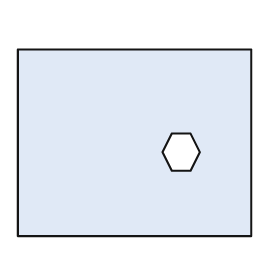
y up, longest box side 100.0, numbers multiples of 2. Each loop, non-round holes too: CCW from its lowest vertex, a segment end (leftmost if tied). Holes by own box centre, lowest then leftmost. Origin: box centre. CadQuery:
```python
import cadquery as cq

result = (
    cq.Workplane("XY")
    .moveTo(-50.0, -40.0)
    .lineTo(50.0, -40.0)
    .lineTo(50.0, 40.0)
    .lineTo(-50.0, 40.0)
    .close()
    .moveTo(16.0, -12.0)
    .lineTo(24.0, -12.0)
    .lineTo(28.0, -4.0)
    .lineTo(24.0, 4.0)
    .lineTo(16.0, 4.0)
    .lineTo(12.0, -4.0)
    .close()
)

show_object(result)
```